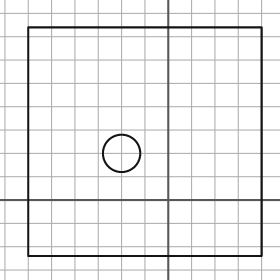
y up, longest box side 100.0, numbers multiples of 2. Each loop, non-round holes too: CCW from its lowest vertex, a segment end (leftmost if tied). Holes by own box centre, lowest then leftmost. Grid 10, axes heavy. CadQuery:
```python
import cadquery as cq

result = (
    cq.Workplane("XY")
    .moveTo(-60.0, -24.0)
    .lineTo(40.0, -24.0)
    .lineTo(40.0, 74.0)
    .lineTo(-60.0, 74.0)
    .close()
    .moveTo(-20.0, 20.0)
    .circle(8.0)
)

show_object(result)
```